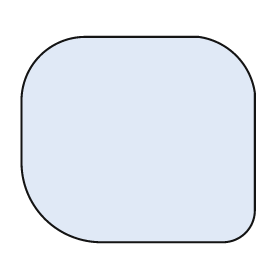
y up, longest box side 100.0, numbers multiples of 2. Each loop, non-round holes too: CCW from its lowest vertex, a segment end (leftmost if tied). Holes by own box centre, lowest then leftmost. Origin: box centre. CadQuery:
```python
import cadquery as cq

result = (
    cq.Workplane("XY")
    .moveTo(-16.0, -44.0)
    .lineTo(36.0, -44.0)
    .threePointArc((46.0, -40.0), (50.0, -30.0))
    .lineTo(50.0, 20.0)
    .threePointArc((42.0, 36.0), (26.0, 44.0))
    .lineTo(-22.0, 44.0)
    .threePointArc((-42.0, 36.0), (-50.0, 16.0))
    .lineTo(-50.0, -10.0)
    .threePointArc((-40.0, -34.0), (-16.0, -44.0))
    .close()
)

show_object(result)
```